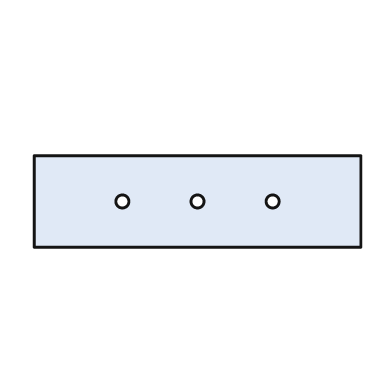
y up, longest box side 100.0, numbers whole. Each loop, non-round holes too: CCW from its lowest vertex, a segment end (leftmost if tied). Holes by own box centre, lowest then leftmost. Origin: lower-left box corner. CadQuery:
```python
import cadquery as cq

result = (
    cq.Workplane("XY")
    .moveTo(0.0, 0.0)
    .lineTo(100.0, 0.0)
    .lineTo(100.0, 28.0)
    .lineTo(0.0, 28.0)
    .close()
    .moveTo(27.0, 14.0)
    .circle(2.0)
    .moveTo(50.0, 14.0)
    .circle(2.0)
    .moveTo(73.0, 14.0)
    .circle(2.0)
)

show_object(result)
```